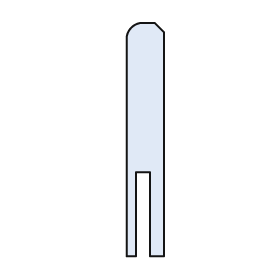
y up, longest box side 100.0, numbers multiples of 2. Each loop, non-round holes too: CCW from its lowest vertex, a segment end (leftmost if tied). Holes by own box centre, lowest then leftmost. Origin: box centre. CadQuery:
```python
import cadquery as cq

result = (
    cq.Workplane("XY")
    .moveTo(-8.0, -50.0)
    .lineTo(-4.0, -50.0)
    .lineTo(-4.0, -14.0)
    .lineTo(2.0, -14.0)
    .lineTo(2.0, -50.0)
    .lineTo(8.0, -50.0)
    .lineTo(8.0, 46.0)
    .lineTo(4.0, 50.0)
    .lineTo(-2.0, 50.0)
    .threePointArc((-6.0, 48.0), (-8.0, 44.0))
    .close()
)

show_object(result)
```